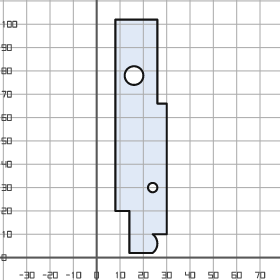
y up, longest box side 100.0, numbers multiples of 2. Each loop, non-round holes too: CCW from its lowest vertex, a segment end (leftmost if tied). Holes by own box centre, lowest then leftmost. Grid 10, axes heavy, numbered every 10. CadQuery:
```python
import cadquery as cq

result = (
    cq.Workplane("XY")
    .moveTo(14.0, 2.0)
    .lineTo(24.0, 2.0)
    .threePointArc((26.0, 6.0), (24.0, 10.0))
    .lineTo(30.0, 10.0)
    .lineTo(30.0, 66.0)
    .lineTo(26.0, 66.0)
    .lineTo(26.0, 102.0)
    .lineTo(8.0, 102.0)
    .lineTo(8.0, 20.0)
    .lineTo(14.0, 20.0)
    .close()
    .moveTo(24.0, 30.0)
    .circle(2.0)
    .moveTo(16.0, 78.0)
    .circle(4.0)
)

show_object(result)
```